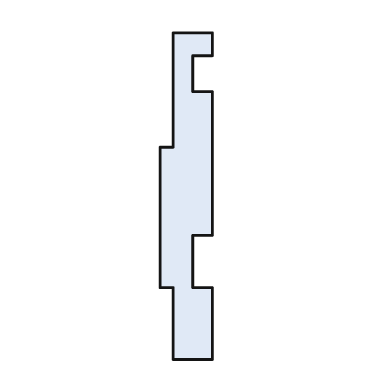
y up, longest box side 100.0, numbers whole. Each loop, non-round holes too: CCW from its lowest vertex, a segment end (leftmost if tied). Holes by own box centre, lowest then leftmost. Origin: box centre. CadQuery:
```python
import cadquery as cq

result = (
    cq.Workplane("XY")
    .moveTo(-4.0, -50.0)
    .lineTo(8.0, -50.0)
    .lineTo(8.0, -28.0)
    .lineTo(2.0, -28.0)
    .lineTo(2.0, -12.0)
    .lineTo(8.0, -12.0)
    .lineTo(8.0, 32.0)
    .lineTo(2.0, 32.0)
    .lineTo(2.0, 43.0)
    .lineTo(8.0, 43.0)
    .lineTo(8.0, 50.0)
    .lineTo(-4.0, 50.0)
    .lineTo(-4.0, 15.0)
    .lineTo(-8.0, 15.0)
    .lineTo(-8.0, -28.0)
    .lineTo(-4.0, -28.0)
    .close()
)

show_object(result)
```